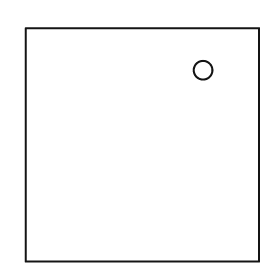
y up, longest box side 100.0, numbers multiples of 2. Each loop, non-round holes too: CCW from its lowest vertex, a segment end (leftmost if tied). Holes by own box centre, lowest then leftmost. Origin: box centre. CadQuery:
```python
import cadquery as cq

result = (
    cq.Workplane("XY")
    .moveTo(-50.0, -50.0)
    .lineTo(50.0, -50.0)
    .lineTo(50.0, 50.0)
    .lineTo(-50.0, 50.0)
    .close()
    .moveTo(26.0, 32.0)
    .circle(4.0)
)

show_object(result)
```